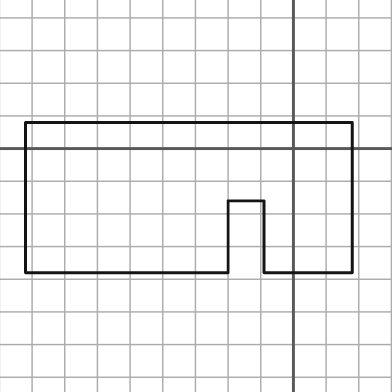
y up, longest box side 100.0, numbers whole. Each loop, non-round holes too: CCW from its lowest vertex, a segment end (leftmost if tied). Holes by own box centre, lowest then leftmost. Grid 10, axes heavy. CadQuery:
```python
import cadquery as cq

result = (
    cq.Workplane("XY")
    .moveTo(-82.0, -38.0)
    .lineTo(-20.0, -38.0)
    .lineTo(-20.0, -16.0)
    .lineTo(-9.0, -16.0)
    .lineTo(-9.0, -38.0)
    .lineTo(18.0, -38.0)
    .lineTo(18.0, 8.0)
    .lineTo(-82.0, 8.0)
    .close()
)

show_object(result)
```